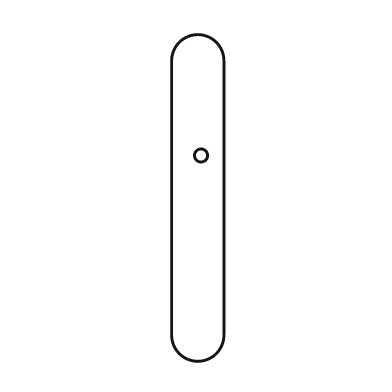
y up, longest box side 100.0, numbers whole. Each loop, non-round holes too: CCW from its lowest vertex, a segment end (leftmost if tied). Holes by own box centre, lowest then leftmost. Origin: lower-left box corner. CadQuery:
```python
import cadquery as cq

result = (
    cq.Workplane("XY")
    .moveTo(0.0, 8.0)
    .threePointArc((8.0, 0.0), (16.0, 8.0))
    .lineTo(16.0, 92.0)
    .threePointArc((8.0, 100.0), (0.0, 92.0))
    .close()
    .moveTo(9.0, 63.0)
    .circle(2.0)
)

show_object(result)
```